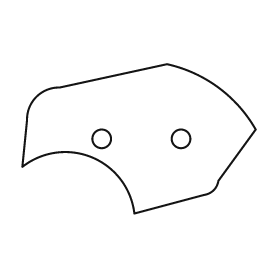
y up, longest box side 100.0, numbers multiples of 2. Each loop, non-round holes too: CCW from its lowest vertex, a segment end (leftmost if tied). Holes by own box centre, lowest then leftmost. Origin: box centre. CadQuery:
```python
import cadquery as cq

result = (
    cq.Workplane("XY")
    .moveTo(-2.0, -32.0)
    .lineTo(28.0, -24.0)
    .threePointArc((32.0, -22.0), (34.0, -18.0))
    .lineTo(50.0, 4.0)
    .threePointArc((34.0, 22.0), (12.0, 32.0))
    .lineTo(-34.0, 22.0)
    .threePointArc((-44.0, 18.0), (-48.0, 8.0))
    .lineTo(-50.0, -12.0)
    .threePointArc((-20.0, -8.0), (-2.0, -32.0))
    .close()
    .moveTo(-16.0, 0.0)
    .circle(4.0)
    .moveTo(18.0, 0.0)
    .circle(4.0)
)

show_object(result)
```